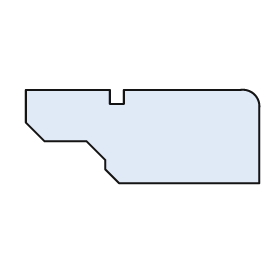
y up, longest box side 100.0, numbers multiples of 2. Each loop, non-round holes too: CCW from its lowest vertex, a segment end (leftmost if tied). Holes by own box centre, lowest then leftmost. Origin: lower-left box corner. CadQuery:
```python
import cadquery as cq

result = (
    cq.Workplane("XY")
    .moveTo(40.0, 0.0)
    .lineTo(100.0, 0.0)
    .lineTo(100.0, 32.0)
    .threePointArc((98.0, 38.0), (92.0, 40.0))
    .lineTo(42.0, 40.0)
    .lineTo(42.0, 34.0)
    .lineTo(36.0, 34.0)
    .lineTo(36.0, 40.0)
    .lineTo(0.0, 40.0)
    .lineTo(0.0, 26.0)
    .lineTo(8.0, 18.0)
    .lineTo(26.0, 18.0)
    .lineTo(34.0, 10.0)
    .lineTo(34.0, 6.0)
    .close()
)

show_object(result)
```